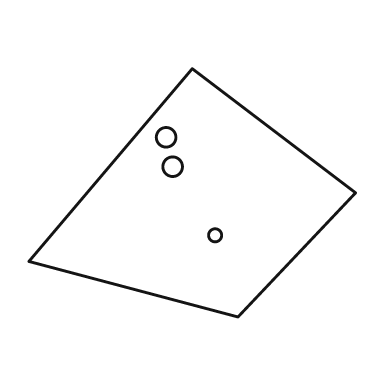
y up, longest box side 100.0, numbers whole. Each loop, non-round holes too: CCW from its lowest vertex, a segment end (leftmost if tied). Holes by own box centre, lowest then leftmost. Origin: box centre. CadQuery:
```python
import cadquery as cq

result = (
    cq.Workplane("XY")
    .moveTo(14.0, -38.0)
    .lineTo(50.0, 0.0)
    .lineTo(0.0, 38.0)
    .lineTo(-50.0, -21.0)
    .close()
    .moveTo(7.0, -13.0)
    .circle(2.0)
    .moveTo(-6.0, 8.0)
    .circle(3.0)
    .moveTo(-8.0, 17.0)
    .circle(3.0)
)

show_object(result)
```